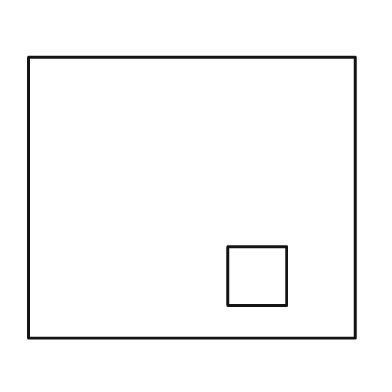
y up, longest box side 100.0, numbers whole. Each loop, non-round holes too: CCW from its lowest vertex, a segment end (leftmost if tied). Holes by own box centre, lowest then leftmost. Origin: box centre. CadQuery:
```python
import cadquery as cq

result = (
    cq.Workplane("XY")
    .moveTo(-50.0, -43.0)
    .lineTo(50.0, -43.0)
    .lineTo(50.0, 43.0)
    .lineTo(-50.0, 43.0)
    .close()
    .moveTo(11.0, -33.0)
    .lineTo(29.0, -33.0)
    .lineTo(29.0, -15.0)
    .lineTo(11.0, -15.0)
    .close()
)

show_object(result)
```